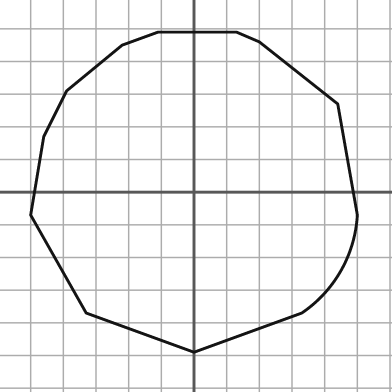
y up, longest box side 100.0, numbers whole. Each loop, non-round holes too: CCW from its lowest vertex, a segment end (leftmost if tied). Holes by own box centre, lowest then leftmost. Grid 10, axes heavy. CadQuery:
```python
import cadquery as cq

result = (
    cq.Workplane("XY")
    .moveTo(0.0, -49.0)
    .lineTo(33.0, -37.0)
    .threePointArc((45.0, -24.0), (50.0, -7.0))
    .lineTo(44.0, 27.0)
    .lineTo(20.0, 46.0)
    .lineTo(13.0, 49.0)
    .lineTo(-11.0, 49.0)
    .lineTo(-22.0, 45.0)
    .lineTo(-39.0, 31.0)
    .lineTo(-46.0, 17.0)
    .lineTo(-50.0, -7.0)
    .lineTo(-33.0, -37.0)
    .close()
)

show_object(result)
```